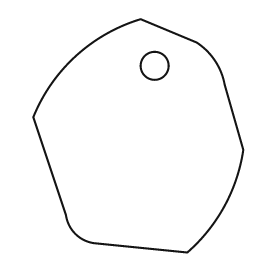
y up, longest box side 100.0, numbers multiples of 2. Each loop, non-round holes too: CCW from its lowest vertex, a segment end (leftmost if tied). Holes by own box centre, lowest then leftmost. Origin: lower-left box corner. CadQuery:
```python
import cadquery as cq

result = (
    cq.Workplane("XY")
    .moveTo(66.0, 0.0)
    .threePointArc((82.0, 20.0), (90.0, 44.0))
    .lineTo(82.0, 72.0)
    .threePointArc((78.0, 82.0), (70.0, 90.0))
    .lineTo(46.0, 100.0)
    .threePointArc((18.0, 84.0), (0.0, 58.0))
    .lineTo(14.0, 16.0)
    .threePointArc((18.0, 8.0), (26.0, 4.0))
    .close()
    .moveTo(52.0, 80.0)
    .circle(6.0)
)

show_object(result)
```